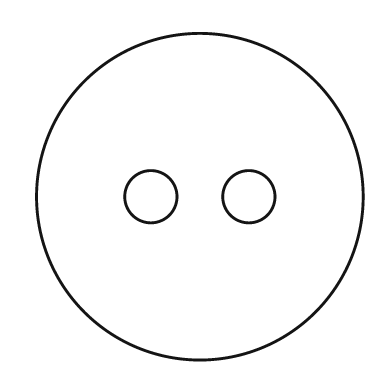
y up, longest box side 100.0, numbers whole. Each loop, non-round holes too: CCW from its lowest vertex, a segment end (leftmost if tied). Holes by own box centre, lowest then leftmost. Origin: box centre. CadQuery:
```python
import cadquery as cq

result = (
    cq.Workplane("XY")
    .moveTo(0.0, 0.0)
    .circle(50.0)
    .moveTo(-15.0, 0.0)
    .circle(8.0)
    .moveTo(15.0, 0.0)
    .circle(8.0)
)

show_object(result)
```